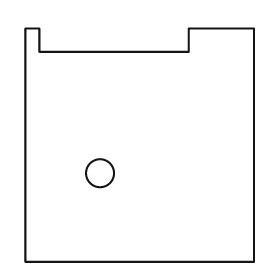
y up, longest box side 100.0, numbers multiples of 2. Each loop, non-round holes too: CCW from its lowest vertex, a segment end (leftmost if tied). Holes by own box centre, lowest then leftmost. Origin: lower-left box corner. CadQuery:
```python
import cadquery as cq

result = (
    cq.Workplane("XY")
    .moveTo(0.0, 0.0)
    .lineTo(98.0, 0.0)
    .lineTo(98.0, 100.0)
    .lineTo(70.0, 100.0)
    .lineTo(70.0, 90.0)
    .lineTo(6.0, 90.0)
    .lineTo(6.0, 100.0)
    .lineTo(0.0, 100.0)
    .close()
    .moveTo(32.0, 38.0)
    .circle(6.0)
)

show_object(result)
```